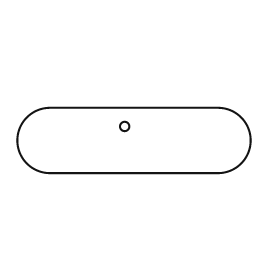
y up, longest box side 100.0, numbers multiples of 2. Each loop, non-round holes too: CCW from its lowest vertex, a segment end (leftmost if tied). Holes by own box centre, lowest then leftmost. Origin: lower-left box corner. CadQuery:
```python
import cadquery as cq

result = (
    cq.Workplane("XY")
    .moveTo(14.0, 0.0)
    .lineTo(86.0, 0.0)
    .threePointArc((100.0, 14.0), (86.0, 28.0))
    .lineTo(14.0, 28.0)
    .threePointArc((0.0, 14.0), (14.0, 0.0))
    .close()
    .moveTo(46.0, 20.0)
    .circle(2.0)
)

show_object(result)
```